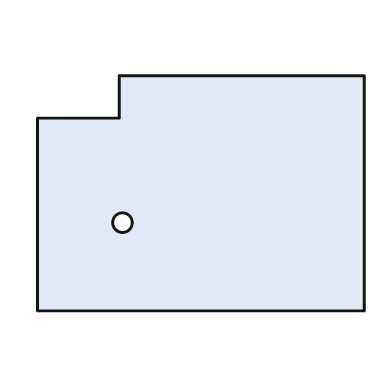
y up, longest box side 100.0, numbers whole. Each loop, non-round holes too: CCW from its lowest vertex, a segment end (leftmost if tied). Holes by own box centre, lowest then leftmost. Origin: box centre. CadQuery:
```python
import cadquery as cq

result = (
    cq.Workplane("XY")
    .moveTo(-50.0, -36.0)
    .lineTo(50.0, -36.0)
    .lineTo(50.0, 36.0)
    .lineTo(-25.0, 36.0)
    .lineTo(-25.0, 23.0)
    .lineTo(-50.0, 23.0)
    .close()
    .moveTo(-24.0, -9.0)
    .circle(3.0)
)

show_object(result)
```